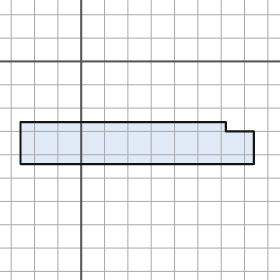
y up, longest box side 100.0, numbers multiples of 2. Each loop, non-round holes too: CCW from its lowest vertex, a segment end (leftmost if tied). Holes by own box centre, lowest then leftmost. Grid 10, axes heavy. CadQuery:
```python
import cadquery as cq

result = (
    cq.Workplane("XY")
    .moveTo(-26.0, -44.0)
    .lineTo(74.0, -44.0)
    .lineTo(74.0, -30.0)
    .lineTo(62.0, -30.0)
    .lineTo(62.0, -26.0)
    .lineTo(-26.0, -26.0)
    .close()
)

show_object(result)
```